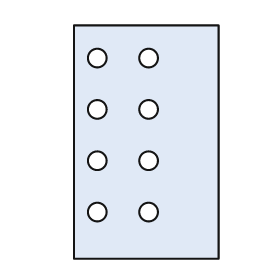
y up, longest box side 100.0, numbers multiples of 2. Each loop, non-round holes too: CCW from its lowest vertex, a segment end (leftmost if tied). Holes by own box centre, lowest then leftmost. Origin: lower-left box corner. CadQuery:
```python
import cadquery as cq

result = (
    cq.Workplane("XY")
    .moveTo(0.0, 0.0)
    .lineTo(62.0, 0.0)
    .lineTo(62.0, 100.0)
    .lineTo(0.0, 100.0)
    .close()
    .moveTo(10.0, 20.0)
    .circle(4.0)
    .moveTo(32.0, 20.0)
    .circle(4.0)
    .moveTo(10.0, 42.0)
    .circle(4.0)
    .moveTo(32.0, 42.0)
    .circle(4.0)
    .moveTo(10.0, 64.0)
    .circle(4.0)
    .moveTo(32.0, 64.0)
    .circle(4.0)
    .moveTo(10.0, 86.0)
    .circle(4.0)
    .moveTo(32.0, 86.0)
    .circle(4.0)
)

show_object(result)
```